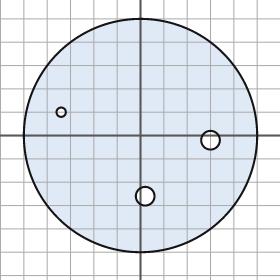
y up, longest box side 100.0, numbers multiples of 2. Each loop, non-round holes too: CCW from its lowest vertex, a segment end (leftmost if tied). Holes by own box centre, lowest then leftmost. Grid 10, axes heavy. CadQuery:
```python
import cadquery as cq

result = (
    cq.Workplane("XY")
    .moveTo(0.0, 0.0)
    .circle(50.0)
    .moveTo(2.0, -26.0)
    .circle(4.0)
    .moveTo(30.0, -2.0)
    .circle(4.0)
    .moveTo(-34.0, 10.0)
    .circle(2.0)
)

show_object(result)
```